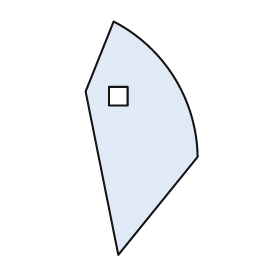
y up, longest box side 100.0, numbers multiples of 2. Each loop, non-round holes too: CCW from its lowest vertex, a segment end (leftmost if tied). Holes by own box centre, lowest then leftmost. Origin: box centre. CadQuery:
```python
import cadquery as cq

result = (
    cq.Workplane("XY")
    .moveTo(-10.0, -50.0)
    .lineTo(24.0, -8.0)
    .threePointArc((14.0, 26.0), (-12.0, 50.0))
    .lineTo(-24.0, 20.0)
    .close()
    .moveTo(-14.0, 14.0)
    .lineTo(-6.0, 14.0)
    .lineTo(-6.0, 22.0)
    .lineTo(-14.0, 22.0)
    .close()
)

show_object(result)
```